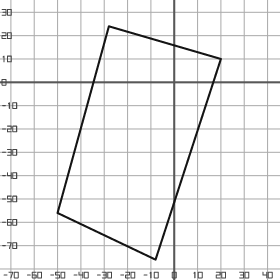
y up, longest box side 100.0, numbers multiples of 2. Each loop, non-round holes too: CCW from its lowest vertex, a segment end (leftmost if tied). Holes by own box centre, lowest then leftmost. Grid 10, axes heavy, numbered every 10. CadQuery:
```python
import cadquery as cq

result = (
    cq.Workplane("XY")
    .moveTo(-8.0, -76.0)
    .lineTo(20.0, 10.0)
    .lineTo(-28.0, 24.0)
    .lineTo(-50.0, -56.0)
    .close()
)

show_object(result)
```